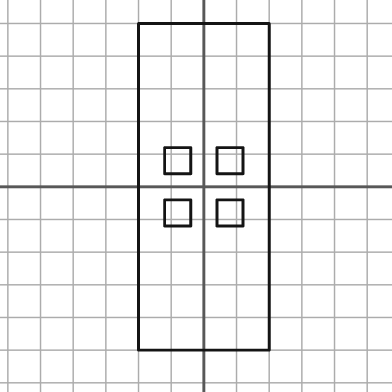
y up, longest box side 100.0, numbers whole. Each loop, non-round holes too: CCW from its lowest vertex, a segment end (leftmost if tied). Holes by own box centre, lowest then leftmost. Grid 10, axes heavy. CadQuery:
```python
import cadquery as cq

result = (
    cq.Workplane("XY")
    .moveTo(-20.0, -50.0)
    .lineTo(20.0, -50.0)
    .lineTo(20.0, 50.0)
    .lineTo(-20.0, 50.0)
    .close()
    .moveTo(-12.0, -12.0)
    .lineTo(-4.0, -12.0)
    .lineTo(-4.0, -4.0)
    .lineTo(-12.0, -4.0)
    .close()
    .moveTo(4.0, -12.0)
    .lineTo(12.0, -12.0)
    .lineTo(12.0, -4.0)
    .lineTo(4.0, -4.0)
    .close()
    .moveTo(-12.0, 4.0)
    .lineTo(-4.0, 4.0)
    .lineTo(-4.0, 12.0)
    .lineTo(-12.0, 12.0)
    .close()
    .moveTo(4.0, 4.0)
    .lineTo(12.0, 4.0)
    .lineTo(12.0, 12.0)
    .lineTo(4.0, 12.0)
    .close()
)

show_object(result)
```